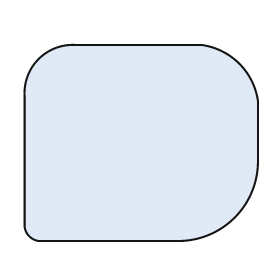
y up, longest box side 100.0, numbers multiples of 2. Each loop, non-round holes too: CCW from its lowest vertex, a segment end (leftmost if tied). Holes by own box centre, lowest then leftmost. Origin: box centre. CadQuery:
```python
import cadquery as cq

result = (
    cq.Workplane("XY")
    .moveTo(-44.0, -42.0)
    .lineTo(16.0, -42.0)
    .threePointArc((40.0, -32.0), (50.0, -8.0))
    .lineTo(50.0, 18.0)
    .threePointArc((42.0, 34.0), (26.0, 42.0))
    .lineTo(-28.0, 42.0)
    .threePointArc((-44.0, 36.0), (-50.0, 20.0))
    .lineTo(-50.0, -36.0)
    .threePointArc((-48.0, -40.0), (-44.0, -42.0))
    .close()
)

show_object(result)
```